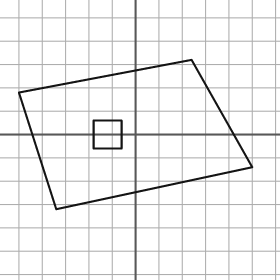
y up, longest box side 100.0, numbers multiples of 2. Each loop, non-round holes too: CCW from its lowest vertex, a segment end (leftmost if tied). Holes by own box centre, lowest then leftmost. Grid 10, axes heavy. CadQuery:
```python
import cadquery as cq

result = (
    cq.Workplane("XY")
    .moveTo(-34.0, -32.0)
    .lineTo(50.0, -14.0)
    .lineTo(24.0, 32.0)
    .lineTo(-50.0, 18.0)
    .close()
    .moveTo(-18.0, -6.0)
    .lineTo(-6.0, -6.0)
    .lineTo(-6.0, 6.0)
    .lineTo(-18.0, 6.0)
    .close()
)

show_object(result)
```